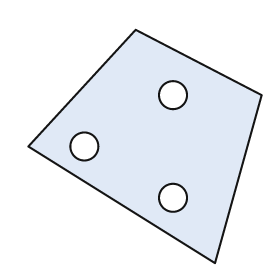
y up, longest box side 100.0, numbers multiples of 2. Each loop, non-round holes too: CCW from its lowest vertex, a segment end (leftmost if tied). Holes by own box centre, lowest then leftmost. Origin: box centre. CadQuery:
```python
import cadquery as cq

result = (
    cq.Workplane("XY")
    .moveTo(30.0, -50.0)
    .lineTo(50.0, 22.0)
    .lineTo(-4.0, 50.0)
    .lineTo(-50.0, 0.0)
    .close()
    .moveTo(12.0, -22.0)
    .circle(6.0)
    .moveTo(-26.0, 0.0)
    .circle(6.0)
    .moveTo(12.0, 22.0)
    .circle(6.0)
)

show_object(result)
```